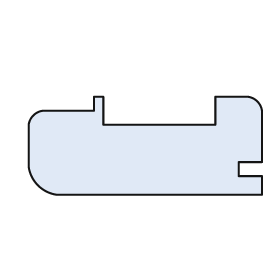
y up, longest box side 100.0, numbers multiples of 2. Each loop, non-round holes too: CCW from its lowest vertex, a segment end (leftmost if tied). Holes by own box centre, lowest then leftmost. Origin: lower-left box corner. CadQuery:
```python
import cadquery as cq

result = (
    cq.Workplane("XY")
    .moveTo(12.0, 0.0)
    .lineTo(100.0, 0.0)
    .lineTo(100.0, 8.0)
    .lineTo(90.0, 8.0)
    .lineTo(90.0, 14.0)
    .lineTo(100.0, 14.0)
    .lineTo(100.0, 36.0)
    .threePointArc((98.0, 40.0), (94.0, 42.0))
    .lineTo(80.0, 42.0)
    .lineTo(80.0, 30.0)
    .lineTo(32.0, 30.0)
    .lineTo(32.0, 42.0)
    .lineTo(28.0, 42.0)
    .lineTo(28.0, 36.0)
    .lineTo(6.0, 36.0)
    .threePointArc((2.0, 34.0), (0.0, 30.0))
    .lineTo(0.0, 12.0)
    .threePointArc((4.0, 4.0), (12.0, 0.0))
    .close()
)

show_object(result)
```